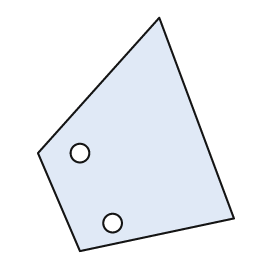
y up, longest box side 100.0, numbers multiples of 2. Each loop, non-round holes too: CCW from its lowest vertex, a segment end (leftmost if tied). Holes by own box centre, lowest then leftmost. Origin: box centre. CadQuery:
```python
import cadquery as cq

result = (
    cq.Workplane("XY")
    .moveTo(-24.0, -50.0)
    .lineTo(42.0, -36.0)
    .lineTo(10.0, 50.0)
    .lineTo(-42.0, -8.0)
    .close()
    .moveTo(-10.0, -38.0)
    .circle(4.0)
    .moveTo(-24.0, -8.0)
    .circle(4.0)
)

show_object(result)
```